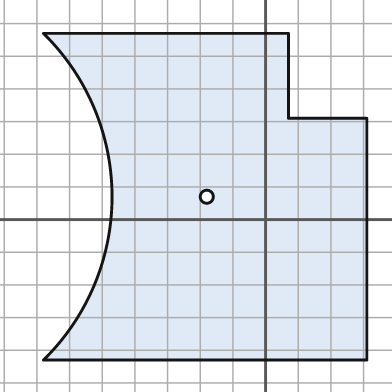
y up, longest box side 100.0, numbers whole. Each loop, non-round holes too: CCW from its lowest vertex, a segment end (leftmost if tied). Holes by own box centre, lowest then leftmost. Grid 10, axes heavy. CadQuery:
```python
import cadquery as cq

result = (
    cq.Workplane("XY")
    .moveTo(-68.0, -43.0)
    .lineTo(31.0, -43.0)
    .lineTo(31.0, 31.0)
    .lineTo(7.0, 31.0)
    .lineTo(7.0, 57.0)
    .lineTo(-68.0, 57.0)
    .threePointArc((-47.0, 7.0), (-68.0, -43.0))
    .close()
    .moveTo(-18.0, 7.0)
    .circle(2.0)
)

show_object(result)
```